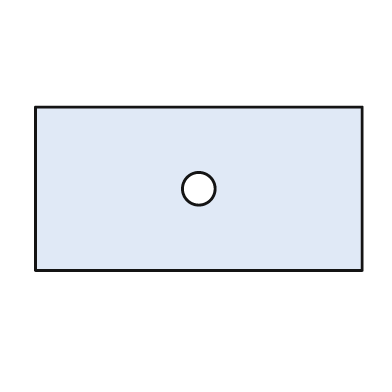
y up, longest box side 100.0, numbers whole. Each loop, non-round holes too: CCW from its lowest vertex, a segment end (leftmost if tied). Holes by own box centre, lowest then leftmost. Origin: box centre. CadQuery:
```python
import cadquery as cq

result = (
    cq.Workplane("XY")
    .moveTo(-50.0, -25.0)
    .lineTo(50.0, -25.0)
    .lineTo(50.0, 25.0)
    .lineTo(-50.0, 25.0)
    .close()
    .moveTo(0.0, 0.0)
    .circle(5.0)
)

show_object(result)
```